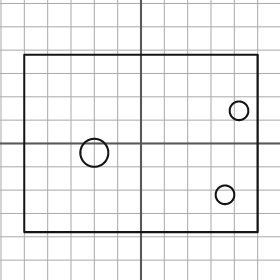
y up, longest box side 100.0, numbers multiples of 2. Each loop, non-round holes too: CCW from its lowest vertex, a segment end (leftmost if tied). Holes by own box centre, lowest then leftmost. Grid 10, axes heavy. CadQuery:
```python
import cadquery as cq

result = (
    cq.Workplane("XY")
    .moveTo(-50.0, -38.0)
    .lineTo(50.0, -38.0)
    .lineTo(50.0, 38.0)
    .lineTo(-50.0, 38.0)
    .close()
    .moveTo(36.0, -22.0)
    .circle(4.0)
    .moveTo(-20.0, -4.0)
    .circle(6.0)
    .moveTo(42.0, 14.0)
    .circle(4.0)
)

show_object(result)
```